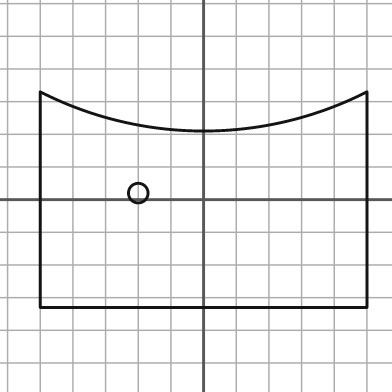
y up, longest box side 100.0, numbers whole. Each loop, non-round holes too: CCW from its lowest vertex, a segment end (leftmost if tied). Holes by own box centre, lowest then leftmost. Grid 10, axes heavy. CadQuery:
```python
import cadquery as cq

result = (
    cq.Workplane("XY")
    .moveTo(-50.0, -33.0)
    .lineTo(50.0, -33.0)
    .lineTo(50.0, 33.0)
    .threePointArc((0.0, 21.0), (-50.0, 33.0))
    .close()
    .moveTo(-20.0, 2.0)
    .circle(3.0)
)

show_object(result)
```